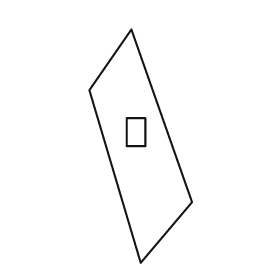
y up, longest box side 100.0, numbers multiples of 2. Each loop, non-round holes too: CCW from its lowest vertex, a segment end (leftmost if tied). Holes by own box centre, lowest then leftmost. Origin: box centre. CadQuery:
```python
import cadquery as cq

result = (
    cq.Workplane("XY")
    .moveTo(0.0, -50.0)
    .lineTo(22.0, -24.0)
    .lineTo(-4.0, 50.0)
    .lineTo(-22.0, 24.0)
    .close()
    .moveTo(-6.0, 0.0)
    .lineTo(2.0, 0.0)
    .lineTo(2.0, 12.0)
    .lineTo(-6.0, 12.0)
    .close()
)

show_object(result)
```